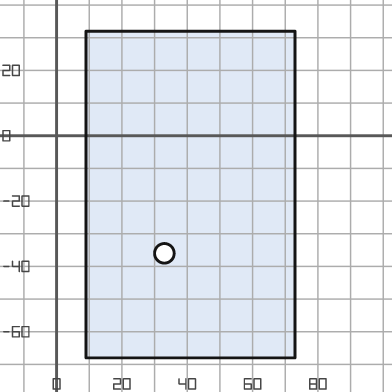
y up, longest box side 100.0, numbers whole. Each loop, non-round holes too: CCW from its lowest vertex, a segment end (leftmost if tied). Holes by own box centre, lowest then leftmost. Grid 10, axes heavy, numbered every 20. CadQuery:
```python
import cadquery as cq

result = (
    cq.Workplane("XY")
    .moveTo(9.0, -68.0)
    .lineTo(73.0, -68.0)
    .lineTo(73.0, 32.0)
    .lineTo(9.0, 32.0)
    .close()
    .moveTo(33.0, -36.0)
    .circle(3.0)
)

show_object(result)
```